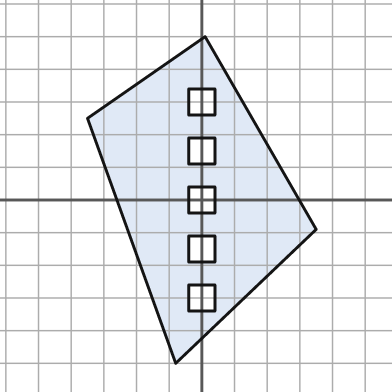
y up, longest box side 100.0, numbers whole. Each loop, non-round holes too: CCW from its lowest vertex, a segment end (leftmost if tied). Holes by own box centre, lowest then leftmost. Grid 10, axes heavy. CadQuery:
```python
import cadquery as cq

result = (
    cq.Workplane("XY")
    .moveTo(-8.0, -50.0)
    .lineTo(35.0, -9.0)
    .lineTo(1.0, 50.0)
    .lineTo(-35.0, 25.0)
    .close()
    .moveTo(-4.0, -34.0)
    .lineTo(4.0, -34.0)
    .lineTo(4.0, -26.0)
    .lineTo(-4.0, -26.0)
    .close()
    .moveTo(-4.0, -19.0)
    .lineTo(4.0, -19.0)
    .lineTo(4.0, -11.0)
    .lineTo(-4.0, -11.0)
    .close()
    .moveTo(-4.0, -4.0)
    .lineTo(4.0, -4.0)
    .lineTo(4.0, 4.0)
    .lineTo(-4.0, 4.0)
    .close()
    .moveTo(-4.0, 11.0)
    .lineTo(4.0, 11.0)
    .lineTo(4.0, 19.0)
    .lineTo(-4.0, 19.0)
    .close()
    .moveTo(-4.0, 26.0)
    .lineTo(4.0, 26.0)
    .lineTo(4.0, 34.0)
    .lineTo(-4.0, 34.0)
    .close()
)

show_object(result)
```